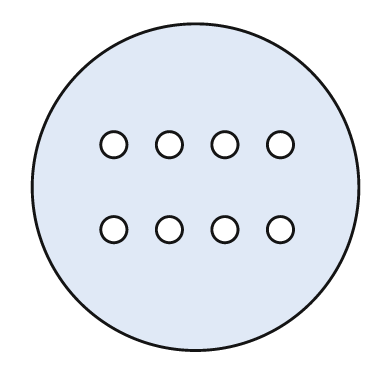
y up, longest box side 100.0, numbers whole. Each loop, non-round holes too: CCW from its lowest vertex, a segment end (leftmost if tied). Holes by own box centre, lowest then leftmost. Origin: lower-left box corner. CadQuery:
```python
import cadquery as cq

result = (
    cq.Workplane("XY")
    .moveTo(50.0, 50.0)
    .circle(50.0)
    .moveTo(25.0, 37.0)
    .circle(4.0)
    .moveTo(42.0, 37.0)
    .circle(4.0)
    .moveTo(59.0, 37.0)
    .circle(4.0)
    .moveTo(76.0, 37.0)
    .circle(4.0)
    .moveTo(25.0, 63.0)
    .circle(4.0)
    .moveTo(42.0, 63.0)
    .circle(4.0)
    .moveTo(59.0, 63.0)
    .circle(4.0)
    .moveTo(76.0, 63.0)
    .circle(4.0)
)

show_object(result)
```